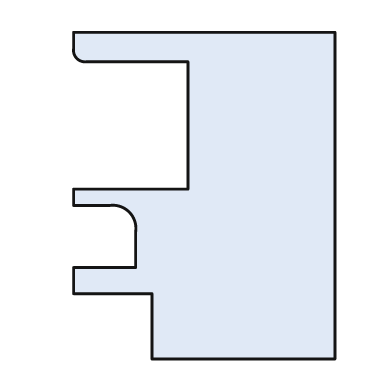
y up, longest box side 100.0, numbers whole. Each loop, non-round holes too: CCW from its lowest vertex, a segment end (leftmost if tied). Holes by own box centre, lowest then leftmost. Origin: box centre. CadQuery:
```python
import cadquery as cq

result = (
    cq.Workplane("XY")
    .moveTo(-16.0, -50.0)
    .lineTo(40.0, -50.0)
    .lineTo(40.0, 50.0)
    .lineTo(-40.0, 50.0)
    .lineTo(-40.0, 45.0)
    .threePointArc((-39.0, 42.0), (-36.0, 41.0))
    .lineTo(-5.0, 41.0)
    .lineTo(-5.0, 2.0)
    .lineTo(-40.0, 2.0)
    .lineTo(-40.0, -3.0)
    .lineTo(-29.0, -3.0)
    .threePointArc((-23.0, -5.0), (-21.0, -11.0))
    .lineTo(-21.0, -22.0)
    .lineTo(-40.0, -22.0)
    .lineTo(-40.0, -30.0)
    .lineTo(-16.0, -30.0)
    .close()
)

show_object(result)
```